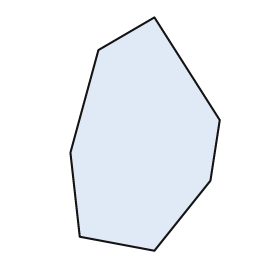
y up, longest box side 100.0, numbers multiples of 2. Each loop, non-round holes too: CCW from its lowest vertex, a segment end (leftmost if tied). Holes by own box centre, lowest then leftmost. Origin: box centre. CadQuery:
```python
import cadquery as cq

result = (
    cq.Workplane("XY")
    .moveTo(4.0, -50.0)
    .lineTo(28.0, -20.0)
    .lineTo(32.0, 6.0)
    .lineTo(4.0, 50.0)
    .lineTo(-20.0, 36.0)
    .lineTo(-32.0, -8.0)
    .lineTo(-28.0, -44.0)
    .close()
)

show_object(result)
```